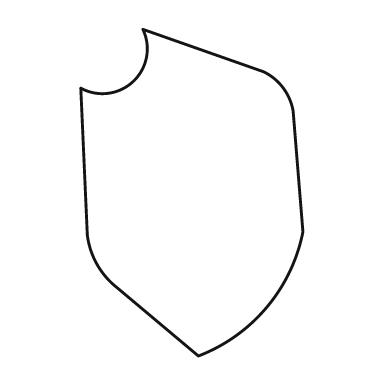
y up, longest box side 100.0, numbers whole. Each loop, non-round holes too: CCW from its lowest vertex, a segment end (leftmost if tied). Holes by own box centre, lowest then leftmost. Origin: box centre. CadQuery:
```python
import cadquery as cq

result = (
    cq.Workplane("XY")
    .moveTo(2.0, -50.0)
    .threePointArc((23.0, -35.0), (34.0, -12.0))
    .lineTo(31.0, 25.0)
    .threePointArc((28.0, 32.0), (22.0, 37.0))
    .lineTo(-15.0, 50.0)
    .threePointArc((-18.0, 34.0), (-34.0, 32.0))
    .lineTo(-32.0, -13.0)
    .threePointArc((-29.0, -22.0), (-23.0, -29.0))
    .close()
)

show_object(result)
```